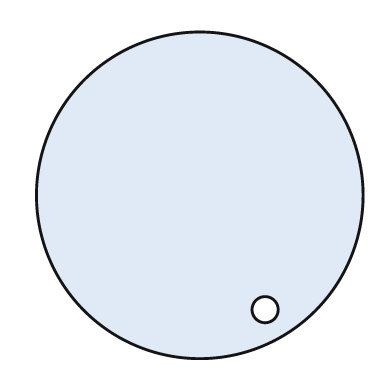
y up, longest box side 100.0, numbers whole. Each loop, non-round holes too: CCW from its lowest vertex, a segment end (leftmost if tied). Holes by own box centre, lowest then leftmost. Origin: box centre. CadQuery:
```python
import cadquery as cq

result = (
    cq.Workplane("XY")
    .moveTo(0.0, 0.0)
    .circle(50.0)
    .moveTo(20.0, -35.0)
    .circle(4.0)
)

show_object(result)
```